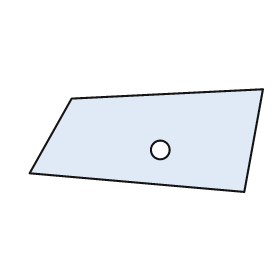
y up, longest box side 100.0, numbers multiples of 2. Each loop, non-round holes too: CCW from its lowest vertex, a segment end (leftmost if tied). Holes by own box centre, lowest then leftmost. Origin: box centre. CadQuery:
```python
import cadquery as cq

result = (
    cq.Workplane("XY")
    .moveTo(42.0, -22.0)
    .lineTo(50.0, 22.0)
    .lineTo(-32.0, 18.0)
    .lineTo(-50.0, -14.0)
    .close()
    .moveTo(6.0, -4.0)
    .circle(4.0)
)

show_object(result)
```